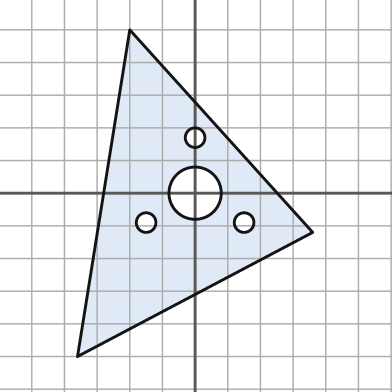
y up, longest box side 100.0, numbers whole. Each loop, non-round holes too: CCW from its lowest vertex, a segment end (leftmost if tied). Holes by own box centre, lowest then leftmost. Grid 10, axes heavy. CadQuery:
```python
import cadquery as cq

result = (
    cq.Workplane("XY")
    .moveTo(-36.0, -50.0)
    .lineTo(36.0, -12.0)
    .lineTo(-20.0, 50.0)
    .close()
    .moveTo(-15.0, -9.0)
    .circle(3.0)
    .moveTo(15.0, -9.0)
    .circle(3.0)
    .moveTo(0.0, 0.0)
    .circle(8.0)
    .moveTo(0.0, 17.0)
    .circle(3.0)
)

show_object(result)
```